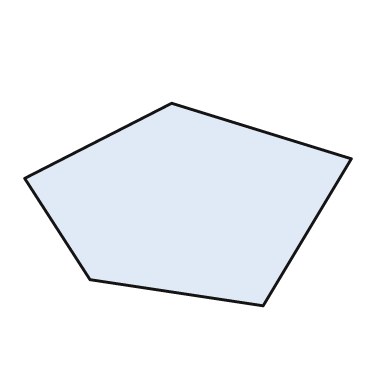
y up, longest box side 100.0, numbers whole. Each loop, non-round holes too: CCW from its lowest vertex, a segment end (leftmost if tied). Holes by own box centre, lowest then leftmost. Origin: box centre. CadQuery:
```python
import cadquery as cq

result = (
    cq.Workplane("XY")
    .moveTo(23.0, -31.0)
    .lineTo(50.0, 14.0)
    .lineTo(-5.0, 31.0)
    .lineTo(-50.0, 8.0)
    .lineTo(-30.0, -23.0)
    .close()
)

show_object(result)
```